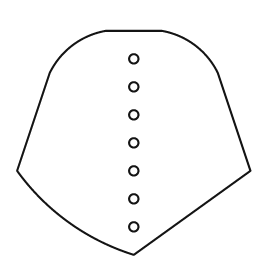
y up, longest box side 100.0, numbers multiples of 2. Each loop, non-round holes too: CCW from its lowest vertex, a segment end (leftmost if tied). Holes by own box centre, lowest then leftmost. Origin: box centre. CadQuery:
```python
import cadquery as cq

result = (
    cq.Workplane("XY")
    .moveTo(0.0, -48.0)
    .lineTo(50.0, -12.0)
    .lineTo(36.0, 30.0)
    .threePointArc((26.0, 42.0), (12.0, 48.0))
    .lineTo(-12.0, 48.0)
    .threePointArc((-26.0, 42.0), (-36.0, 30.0))
    .lineTo(-50.0, -12.0)
    .threePointArc((-28.0, -34.0), (0.0, -48.0))
    .close()
    .moveTo(0.0, -36.0)
    .circle(2.0)
    .moveTo(0.0, -24.0)
    .circle(2.0)
    .moveTo(0.0, -12.0)
    .circle(2.0)
    .moveTo(0.0, 0.0)
    .circle(2.0)
    .moveTo(0.0, 12.0)
    .circle(2.0)
    .moveTo(0.0, 24.0)
    .circle(2.0)
    .moveTo(0.0, 36.0)
    .circle(2.0)
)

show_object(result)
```